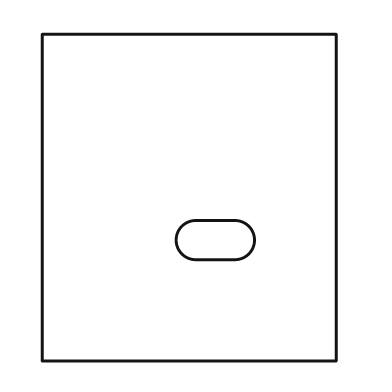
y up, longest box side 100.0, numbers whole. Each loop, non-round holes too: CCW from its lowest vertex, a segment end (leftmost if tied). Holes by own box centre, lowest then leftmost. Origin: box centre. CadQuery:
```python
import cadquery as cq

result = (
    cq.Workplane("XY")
    .moveTo(-45.0, -50.0)
    .lineTo(45.0, -50.0)
    .lineTo(45.0, 50.0)
    .lineTo(-45.0, 50.0)
    .close()
    .moveTo(2.0, -19.0)
    .lineTo(14.0, -19.0)
    .threePointArc((20.0, -13.0), (14.0, -7.0))
    .lineTo(2.0, -7.0)
    .threePointArc((-4.0, -13.0), (2.0, -19.0))
    .close()
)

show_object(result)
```